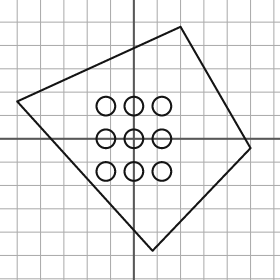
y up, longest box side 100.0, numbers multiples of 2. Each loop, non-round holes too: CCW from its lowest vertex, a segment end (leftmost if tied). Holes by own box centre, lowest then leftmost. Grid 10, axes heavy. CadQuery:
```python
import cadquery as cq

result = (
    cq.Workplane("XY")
    .moveTo(8.0, -48.0)
    .lineTo(50.0, -4.0)
    .lineTo(20.0, 48.0)
    .lineTo(-50.0, 16.0)
    .close()
    .moveTo(-12.0, -14.0)
    .circle(4.0)
    .moveTo(0.0, -14.0)
    .circle(4.0)
    .moveTo(12.0, -14.0)
    .circle(4.0)
    .moveTo(-12.0, 0.0)
    .circle(4.0)
    .moveTo(0.0, 0.0)
    .circle(4.0)
    .moveTo(12.0, 0.0)
    .circle(4.0)
    .moveTo(-12.0, 14.0)
    .circle(4.0)
    .moveTo(0.0, 14.0)
    .circle(4.0)
    .moveTo(12.0, 14.0)
    .circle(4.0)
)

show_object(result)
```